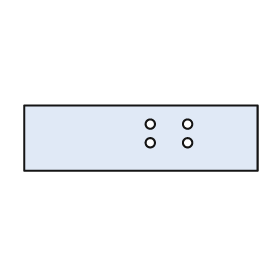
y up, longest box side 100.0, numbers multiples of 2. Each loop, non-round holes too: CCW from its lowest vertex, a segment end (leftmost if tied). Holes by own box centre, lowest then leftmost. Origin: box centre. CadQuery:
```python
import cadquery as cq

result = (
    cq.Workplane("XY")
    .moveTo(-50.0, -14.0)
    .lineTo(50.0, -14.0)
    .lineTo(50.0, 14.0)
    .lineTo(-50.0, 14.0)
    .close()
    .moveTo(4.0, -2.0)
    .circle(2.0)
    .moveTo(20.0, -2.0)
    .circle(2.0)
    .moveTo(4.0, 6.0)
    .circle(2.0)
    .moveTo(20.0, 6.0)
    .circle(2.0)
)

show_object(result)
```